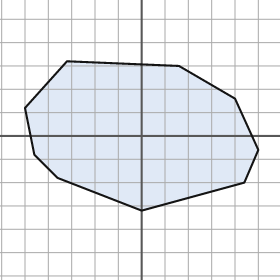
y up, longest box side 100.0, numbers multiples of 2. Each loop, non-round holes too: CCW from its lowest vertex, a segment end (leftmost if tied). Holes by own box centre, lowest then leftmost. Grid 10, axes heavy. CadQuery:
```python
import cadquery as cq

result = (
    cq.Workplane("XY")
    .moveTo(0.0, -32.0)
    .lineTo(44.0, -20.0)
    .lineTo(50.0, -6.0)
    .lineTo(40.0, 16.0)
    .lineTo(16.0, 30.0)
    .lineTo(-32.0, 32.0)
    .lineTo(-50.0, 12.0)
    .lineTo(-46.0, -8.0)
    .lineTo(-36.0, -18.0)
    .close()
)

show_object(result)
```